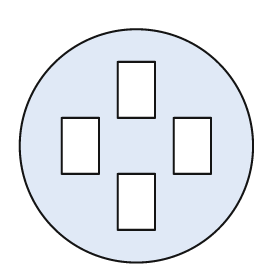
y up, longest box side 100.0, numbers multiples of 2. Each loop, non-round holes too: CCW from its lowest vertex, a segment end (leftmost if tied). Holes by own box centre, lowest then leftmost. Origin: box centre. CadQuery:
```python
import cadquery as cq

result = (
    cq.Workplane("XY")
    .moveTo(0.0, 0.0)
    .circle(50.0)
    .moveTo(-8.0, -36.0)
    .lineTo(8.0, -36.0)
    .lineTo(8.0, -12.0)
    .lineTo(-8.0, -12.0)
    .close()
    .moveTo(-32.0, -12.0)
    .lineTo(-16.0, -12.0)
    .lineTo(-16.0, 12.0)
    .lineTo(-32.0, 12.0)
    .close()
    .moveTo(16.0, -12.0)
    .lineTo(32.0, -12.0)
    .lineTo(32.0, 12.0)
    .lineTo(16.0, 12.0)
    .close()
    .moveTo(-8.0, 12.0)
    .lineTo(8.0, 12.0)
    .lineTo(8.0, 36.0)
    .lineTo(-8.0, 36.0)
    .close()
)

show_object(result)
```